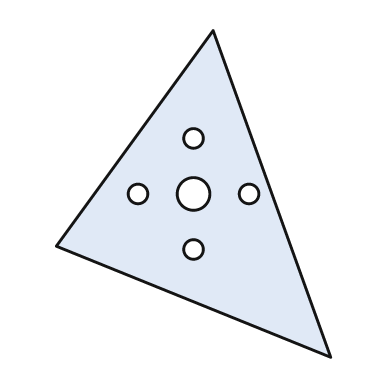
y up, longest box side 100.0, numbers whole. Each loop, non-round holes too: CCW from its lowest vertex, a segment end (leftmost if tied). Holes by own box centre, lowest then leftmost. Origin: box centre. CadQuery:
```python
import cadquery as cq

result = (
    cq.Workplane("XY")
    .moveTo(42.0, -50.0)
    .lineTo(6.0, 50.0)
    .lineTo(-42.0, -16.0)
    .close()
    .moveTo(0.0, -17.0)
    .circle(3.0)
    .moveTo(-17.0, 0.0)
    .circle(3.0)
    .moveTo(0.0, 0.0)
    .circle(5.0)
    .moveTo(17.0, 0.0)
    .circle(3.0)
    .moveTo(0.0, 17.0)
    .circle(3.0)
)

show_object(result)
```